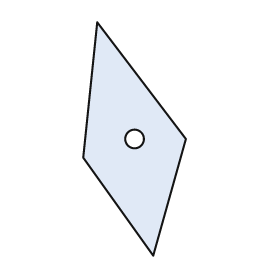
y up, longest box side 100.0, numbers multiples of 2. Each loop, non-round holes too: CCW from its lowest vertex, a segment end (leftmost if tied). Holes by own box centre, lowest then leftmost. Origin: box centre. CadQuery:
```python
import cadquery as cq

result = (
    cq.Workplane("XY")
    .moveTo(8.0, -50.0)
    .lineTo(22.0, 0.0)
    .lineTo(-16.0, 50.0)
    .lineTo(-22.0, -8.0)
    .close()
    .moveTo(0.0, 0.0)
    .circle(4.0)
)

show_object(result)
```